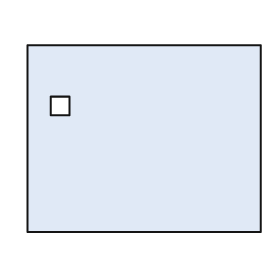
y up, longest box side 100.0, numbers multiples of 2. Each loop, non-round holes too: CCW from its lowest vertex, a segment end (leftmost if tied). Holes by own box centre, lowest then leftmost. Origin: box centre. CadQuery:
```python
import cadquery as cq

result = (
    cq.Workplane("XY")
    .moveTo(-50.0, -40.0)
    .lineTo(50.0, -40.0)
    .lineTo(50.0, 40.0)
    .lineTo(-50.0, 40.0)
    .close()
    .moveTo(-40.0, 10.0)
    .lineTo(-32.0, 10.0)
    .lineTo(-32.0, 18.0)
    .lineTo(-40.0, 18.0)
    .close()
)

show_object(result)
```